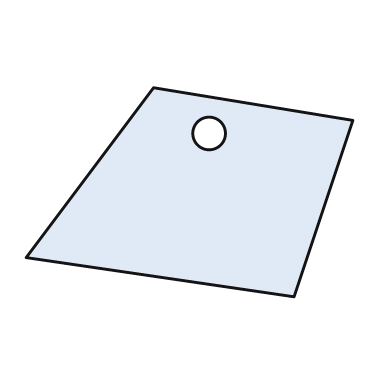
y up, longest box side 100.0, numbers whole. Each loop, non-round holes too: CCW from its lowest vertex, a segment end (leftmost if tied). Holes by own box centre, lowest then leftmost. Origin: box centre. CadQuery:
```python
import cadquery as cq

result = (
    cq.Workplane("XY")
    .moveTo(32.0, -32.0)
    .lineTo(50.0, 22.0)
    .lineTo(-11.0, 32.0)
    .lineTo(-50.0, -20.0)
    .close()
    .moveTo(6.0, 18.0)
    .circle(5.0)
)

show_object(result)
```